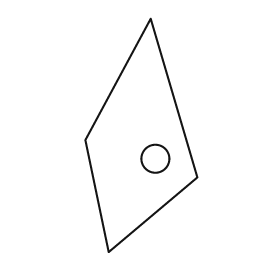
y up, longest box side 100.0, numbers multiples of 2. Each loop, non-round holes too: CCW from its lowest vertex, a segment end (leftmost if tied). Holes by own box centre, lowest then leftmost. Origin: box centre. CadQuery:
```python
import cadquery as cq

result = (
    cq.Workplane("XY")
    .moveTo(-14.0, -50.0)
    .lineTo(24.0, -18.0)
    .lineTo(4.0, 50.0)
    .lineTo(-24.0, -2.0)
    .close()
    .moveTo(6.0, -10.0)
    .circle(6.0)
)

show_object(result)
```